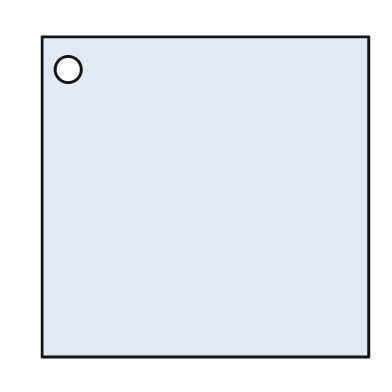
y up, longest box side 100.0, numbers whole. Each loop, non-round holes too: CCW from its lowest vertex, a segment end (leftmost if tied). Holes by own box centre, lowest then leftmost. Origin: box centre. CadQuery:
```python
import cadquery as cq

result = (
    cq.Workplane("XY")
    .moveTo(-50.0, -49.0)
    .lineTo(50.0, -49.0)
    .lineTo(50.0, 49.0)
    .lineTo(-50.0, 49.0)
    .close()
    .moveTo(-42.0, 39.0)
    .circle(4.0)
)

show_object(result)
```